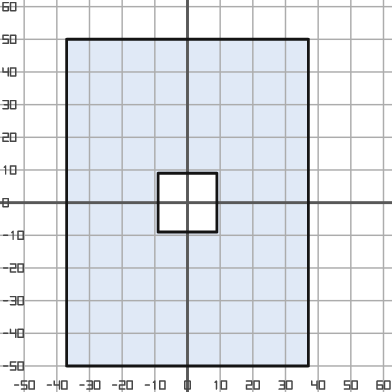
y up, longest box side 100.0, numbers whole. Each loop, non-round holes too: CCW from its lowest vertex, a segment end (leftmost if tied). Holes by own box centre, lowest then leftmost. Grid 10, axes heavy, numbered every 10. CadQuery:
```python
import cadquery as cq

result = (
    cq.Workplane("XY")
    .moveTo(-37.0, -50.0)
    .lineTo(37.0, -50.0)
    .lineTo(37.0, 50.0)
    .lineTo(-37.0, 50.0)
    .close()
    .moveTo(-9.0, -9.0)
    .lineTo(9.0, -9.0)
    .lineTo(9.0, 9.0)
    .lineTo(-9.0, 9.0)
    .close()
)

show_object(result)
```